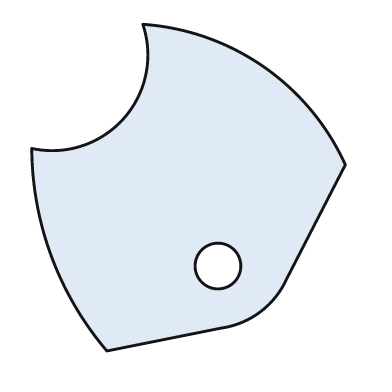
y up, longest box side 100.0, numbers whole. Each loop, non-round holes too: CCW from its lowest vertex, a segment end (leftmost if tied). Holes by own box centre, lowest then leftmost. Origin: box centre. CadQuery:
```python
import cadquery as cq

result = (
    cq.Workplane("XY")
    .moveTo(-25.0, -50.0)
    .lineTo(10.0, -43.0)
    .threePointArc((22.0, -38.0), (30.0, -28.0))
    .lineTo(48.0, 7.0)
    .threePointArc((23.0, 37.0), (-14.0, 50.0))
    .threePointArc((-20.0, 21.0), (-48.0, 12.0))
    .threePointArc((-42.0, -21.0), (-25.0, -50.0))
    .close()
    .moveTo(9.0, -24.0)
    .circle(7.0)
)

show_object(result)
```